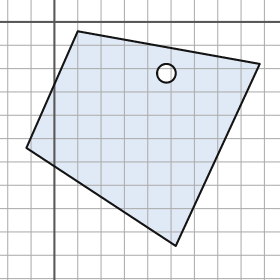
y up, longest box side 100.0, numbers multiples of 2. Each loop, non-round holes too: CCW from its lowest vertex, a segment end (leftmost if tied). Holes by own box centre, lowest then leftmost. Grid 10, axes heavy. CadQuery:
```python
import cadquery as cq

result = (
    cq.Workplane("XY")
    .moveTo(52.0, -96.0)
    .lineTo(88.0, -18.0)
    .lineTo(10.0, -4.0)
    .lineTo(-12.0, -54.0)
    .close()
    .moveTo(48.0, -22.0)
    .circle(4.0)
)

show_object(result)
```